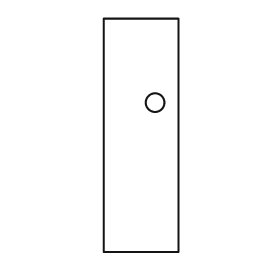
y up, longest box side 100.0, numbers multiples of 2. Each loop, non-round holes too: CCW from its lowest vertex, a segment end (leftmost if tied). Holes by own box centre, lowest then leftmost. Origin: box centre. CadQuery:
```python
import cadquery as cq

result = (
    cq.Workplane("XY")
    .moveTo(-16.0, -50.0)
    .lineTo(16.0, -50.0)
    .lineTo(16.0, 50.0)
    .lineTo(-16.0, 50.0)
    .close()
    .moveTo(6.0, 14.0)
    .circle(4.0)
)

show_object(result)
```